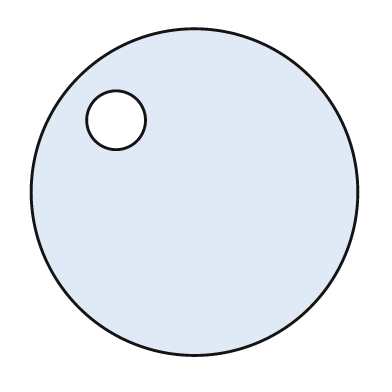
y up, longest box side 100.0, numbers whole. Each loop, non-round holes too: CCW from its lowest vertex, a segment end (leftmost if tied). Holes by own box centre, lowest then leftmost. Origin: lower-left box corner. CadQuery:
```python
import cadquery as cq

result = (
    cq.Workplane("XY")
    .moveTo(50.0, 50.0)
    .circle(50.0)
    .moveTo(26.0, 72.0)
    .circle(9.0)
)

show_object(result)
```